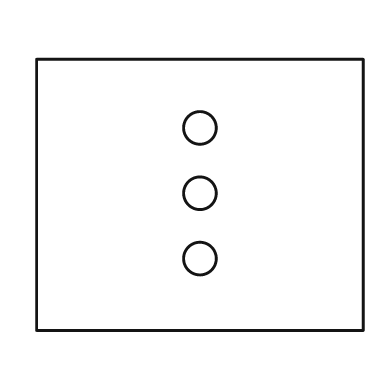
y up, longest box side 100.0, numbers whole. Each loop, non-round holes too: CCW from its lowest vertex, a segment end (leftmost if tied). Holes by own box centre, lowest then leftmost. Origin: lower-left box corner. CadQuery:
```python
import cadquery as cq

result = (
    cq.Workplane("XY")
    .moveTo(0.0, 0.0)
    .lineTo(100.0, 0.0)
    .lineTo(100.0, 83.0)
    .lineTo(0.0, 83.0)
    .close()
    .moveTo(50.0, 22.0)
    .circle(5.0)
    .moveTo(50.0, 42.0)
    .circle(5.0)
    .moveTo(50.0, 62.0)
    .circle(5.0)
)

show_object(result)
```